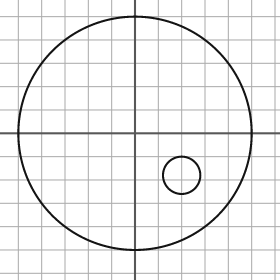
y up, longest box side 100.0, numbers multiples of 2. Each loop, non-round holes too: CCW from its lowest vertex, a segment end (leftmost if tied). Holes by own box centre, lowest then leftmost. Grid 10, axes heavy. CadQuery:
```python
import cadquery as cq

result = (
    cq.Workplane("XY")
    .moveTo(0.0, 0.0)
    .circle(50.0)
    .moveTo(20.0, -18.0)
    .circle(8.0)
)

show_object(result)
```